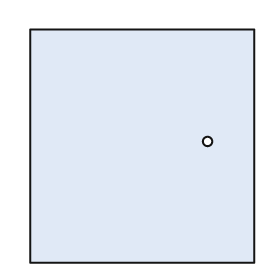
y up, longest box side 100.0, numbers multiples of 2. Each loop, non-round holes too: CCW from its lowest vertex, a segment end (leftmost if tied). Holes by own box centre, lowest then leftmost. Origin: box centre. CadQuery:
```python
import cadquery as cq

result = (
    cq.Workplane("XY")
    .moveTo(-48.0, -50.0)
    .lineTo(48.0, -50.0)
    .lineTo(48.0, 50.0)
    .lineTo(-48.0, 50.0)
    .close()
    .moveTo(28.0, 2.0)
    .circle(2.0)
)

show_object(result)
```